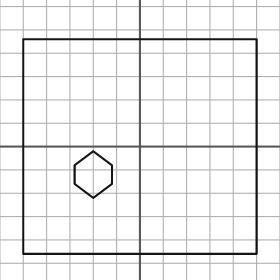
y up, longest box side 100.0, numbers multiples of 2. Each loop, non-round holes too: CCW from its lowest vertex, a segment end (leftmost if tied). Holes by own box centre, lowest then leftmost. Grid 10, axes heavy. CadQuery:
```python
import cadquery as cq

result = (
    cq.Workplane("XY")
    .moveTo(-50.0, -46.0)
    .lineTo(50.0, -46.0)
    .lineTo(50.0, 46.0)
    .lineTo(-50.0, 46.0)
    .close()
    .moveTo(-20.0, -22.0)
    .lineTo(-12.0, -16.0)
    .lineTo(-12.0, -8.0)
    .lineTo(-20.0, -2.0)
    .lineTo(-28.0, -8.0)
    .lineTo(-28.0, -16.0)
    .close()
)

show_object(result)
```